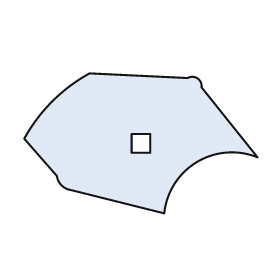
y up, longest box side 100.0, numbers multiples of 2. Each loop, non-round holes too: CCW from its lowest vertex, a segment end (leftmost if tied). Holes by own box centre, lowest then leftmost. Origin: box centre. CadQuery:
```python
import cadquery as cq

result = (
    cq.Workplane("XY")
    .moveTo(10.0, -30.0)
    .threePointArc((24.0, -8.0), (50.0, -6.0))
    .lineTo(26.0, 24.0)
    .threePointArc((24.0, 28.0), (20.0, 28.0))
    .lineTo(-22.0, 30.0)
    .threePointArc((-38.0, 18.0), (-50.0, 2.0))
    .lineTo(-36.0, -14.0)
    .threePointArc((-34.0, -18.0), (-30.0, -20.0))
    .close()
    .moveTo(-4.0, -4.0)
    .lineTo(4.0, -4.0)
    .lineTo(4.0, 4.0)
    .lineTo(-4.0, 4.0)
    .close()
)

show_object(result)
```